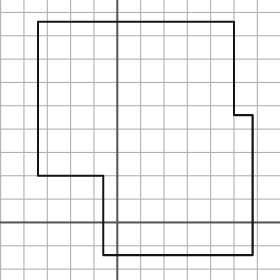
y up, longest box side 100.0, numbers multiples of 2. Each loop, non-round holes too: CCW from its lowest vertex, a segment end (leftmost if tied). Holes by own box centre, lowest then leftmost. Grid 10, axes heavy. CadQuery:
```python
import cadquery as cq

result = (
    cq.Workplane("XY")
    .moveTo(-6.0, -14.0)
    .lineTo(58.0, -14.0)
    .lineTo(58.0, 46.0)
    .lineTo(50.0, 46.0)
    .lineTo(50.0, 86.0)
    .lineTo(-34.0, 86.0)
    .lineTo(-34.0, 20.0)
    .lineTo(-6.0, 20.0)
    .close()
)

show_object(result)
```